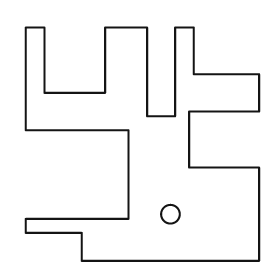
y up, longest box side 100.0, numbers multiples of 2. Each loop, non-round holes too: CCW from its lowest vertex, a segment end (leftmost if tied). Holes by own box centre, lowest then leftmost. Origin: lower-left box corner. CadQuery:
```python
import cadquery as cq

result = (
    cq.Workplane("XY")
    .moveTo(24.0, 0.0)
    .lineTo(100.0, 0.0)
    .lineTo(100.0, 40.0)
    .lineTo(70.0, 40.0)
    .lineTo(70.0, 64.0)
    .lineTo(100.0, 64.0)
    .lineTo(100.0, 80.0)
    .lineTo(72.0, 80.0)
    .lineTo(72.0, 100.0)
    .lineTo(64.0, 100.0)
    .lineTo(64.0, 62.0)
    .lineTo(52.0, 62.0)
    .lineTo(52.0, 100.0)
    .lineTo(34.0, 100.0)
    .lineTo(34.0, 72.0)
    .lineTo(8.0, 72.0)
    .lineTo(8.0, 100.0)
    .lineTo(0.0, 100.0)
    .lineTo(0.0, 56.0)
    .lineTo(44.0, 56.0)
    .lineTo(44.0, 18.0)
    .lineTo(0.0, 18.0)
    .lineTo(0.0, 12.0)
    .lineTo(24.0, 12.0)
    .close()
    .moveTo(62.0, 20.0)
    .circle(4.0)
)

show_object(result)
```